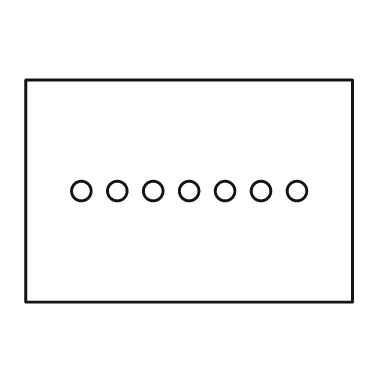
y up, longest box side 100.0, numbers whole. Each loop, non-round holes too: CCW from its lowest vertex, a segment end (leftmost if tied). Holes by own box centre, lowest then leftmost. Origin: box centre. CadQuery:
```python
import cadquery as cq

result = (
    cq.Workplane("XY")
    .moveTo(-50.0, -34.0)
    .lineTo(50.0, -34.0)
    .lineTo(50.0, 34.0)
    .lineTo(-50.0, 34.0)
    .close()
    .moveTo(-33.0, 0.0)
    .circle(3.0)
    .moveTo(-22.0, 0.0)
    .circle(3.0)
    .moveTo(-11.0, 0.0)
    .circle(3.0)
    .moveTo(0.0, 0.0)
    .circle(3.0)
    .moveTo(11.0, 0.0)
    .circle(3.0)
    .moveTo(22.0, 0.0)
    .circle(3.0)
    .moveTo(33.0, 0.0)
    .circle(3.0)
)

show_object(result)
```